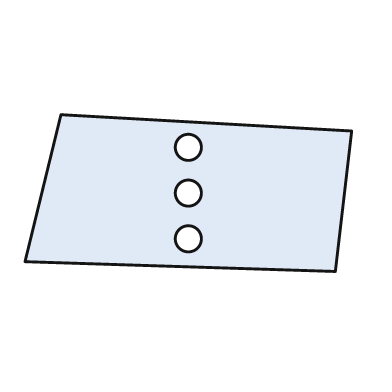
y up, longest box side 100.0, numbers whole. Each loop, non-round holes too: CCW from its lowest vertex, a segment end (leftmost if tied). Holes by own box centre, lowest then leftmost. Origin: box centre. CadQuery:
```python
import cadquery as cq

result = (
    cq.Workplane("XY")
    .moveTo(45.0, -24.0)
    .lineTo(50.0, 19.0)
    .lineTo(-39.0, 24.0)
    .lineTo(-50.0, -21.0)
    .close()
    .moveTo(0.0, -14.0)
    .circle(4.0)
    .moveTo(0.0, 0.0)
    .circle(4.0)
    .moveTo(0.0, 14.0)
    .circle(4.0)
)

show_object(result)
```